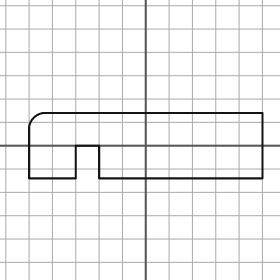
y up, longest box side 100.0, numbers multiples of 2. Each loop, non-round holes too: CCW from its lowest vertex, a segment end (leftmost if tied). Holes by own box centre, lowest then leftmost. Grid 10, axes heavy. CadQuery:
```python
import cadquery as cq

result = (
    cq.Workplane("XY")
    .moveTo(-50.0, -14.0)
    .lineTo(-30.0, -14.0)
    .lineTo(-30.0, 0.0)
    .lineTo(-20.0, 0.0)
    .lineTo(-20.0, -14.0)
    .lineTo(50.0, -14.0)
    .lineTo(50.0, 14.0)
    .lineTo(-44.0, 14.0)
    .threePointArc((-48.0, 12.0), (-50.0, 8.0))
    .close()
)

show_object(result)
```